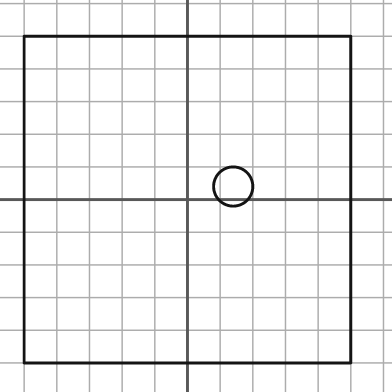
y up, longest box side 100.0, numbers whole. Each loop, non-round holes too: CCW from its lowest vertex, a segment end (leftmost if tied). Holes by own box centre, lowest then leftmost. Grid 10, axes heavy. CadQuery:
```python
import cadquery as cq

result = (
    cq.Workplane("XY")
    .moveTo(-50.0, -50.0)
    .lineTo(50.0, -50.0)
    .lineTo(50.0, 50.0)
    .lineTo(-50.0, 50.0)
    .close()
    .moveTo(14.0, 4.0)
    .circle(6.0)
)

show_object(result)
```